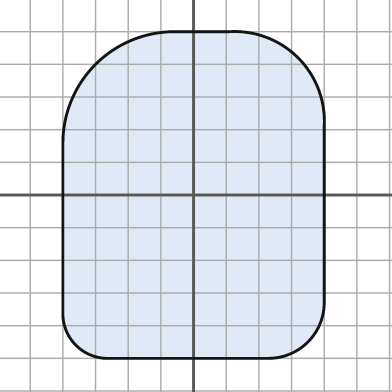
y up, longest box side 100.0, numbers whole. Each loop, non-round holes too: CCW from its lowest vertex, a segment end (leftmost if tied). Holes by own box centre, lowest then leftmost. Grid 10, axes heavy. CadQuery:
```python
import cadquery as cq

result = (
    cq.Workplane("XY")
    .moveTo(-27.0, -50.0)
    .lineTo(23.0, -50.0)
    .threePointArc((35.0, -45.0), (40.0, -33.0))
    .lineTo(40.0, 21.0)
    .threePointArc((32.0, 42.0), (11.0, 50.0))
    .lineTo(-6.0, 50.0)
    .threePointArc((-30.0, 40.0), (-40.0, 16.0))
    .lineTo(-40.0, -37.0)
    .threePointArc((-36.0, -46.0), (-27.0, -50.0))
    .close()
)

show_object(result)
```